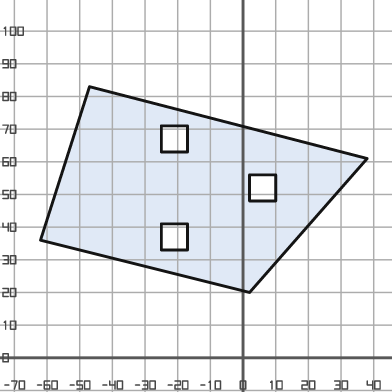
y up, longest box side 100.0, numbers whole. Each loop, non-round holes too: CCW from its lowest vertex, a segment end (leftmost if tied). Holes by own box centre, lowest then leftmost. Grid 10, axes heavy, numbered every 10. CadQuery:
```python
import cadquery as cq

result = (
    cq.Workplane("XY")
    .moveTo(2.0, 20.0)
    .lineTo(38.0, 61.0)
    .lineTo(-47.0, 83.0)
    .lineTo(-62.0, 36.0)
    .close()
    .moveTo(-25.0, 33.0)
    .lineTo(-17.0, 33.0)
    .lineTo(-17.0, 41.0)
    .lineTo(-25.0, 41.0)
    .close()
    .moveTo(2.0, 48.0)
    .lineTo(10.0, 48.0)
    .lineTo(10.0, 56.0)
    .lineTo(2.0, 56.0)
    .close()
    .moveTo(-25.0, 63.0)
    .lineTo(-17.0, 63.0)
    .lineTo(-17.0, 71.0)
    .lineTo(-25.0, 71.0)
    .close()
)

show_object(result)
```